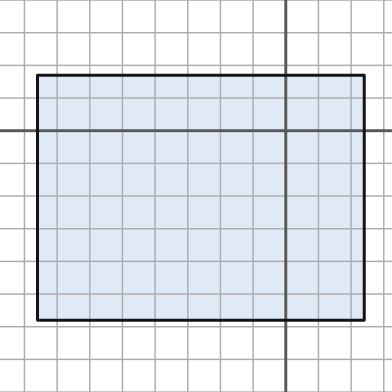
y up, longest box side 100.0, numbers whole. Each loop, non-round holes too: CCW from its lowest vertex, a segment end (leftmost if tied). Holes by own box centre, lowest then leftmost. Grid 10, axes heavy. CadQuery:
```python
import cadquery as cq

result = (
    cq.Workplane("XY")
    .moveTo(-76.0, -58.0)
    .lineTo(24.0, -58.0)
    .lineTo(24.0, 17.0)
    .lineTo(-76.0, 17.0)
    .close()
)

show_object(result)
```